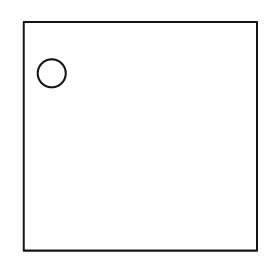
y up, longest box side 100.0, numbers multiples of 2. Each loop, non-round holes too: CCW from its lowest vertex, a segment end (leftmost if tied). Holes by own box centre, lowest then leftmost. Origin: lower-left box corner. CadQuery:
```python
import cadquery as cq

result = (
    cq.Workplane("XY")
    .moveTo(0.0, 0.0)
    .lineTo(100.0, 0.0)
    .lineTo(100.0, 98.0)
    .lineTo(0.0, 98.0)
    .close()
    .moveTo(12.0, 76.0)
    .circle(6.0)
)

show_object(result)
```